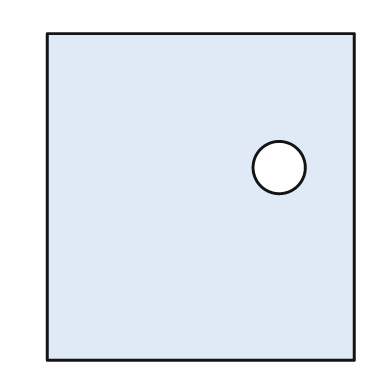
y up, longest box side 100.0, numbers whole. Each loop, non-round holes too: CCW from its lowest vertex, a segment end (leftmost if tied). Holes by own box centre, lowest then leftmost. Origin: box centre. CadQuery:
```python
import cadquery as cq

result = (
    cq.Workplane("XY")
    .moveTo(-47.0, -50.0)
    .lineTo(47.0, -50.0)
    .lineTo(47.0, 50.0)
    .lineTo(-47.0, 50.0)
    .close()
    .moveTo(24.0, 9.0)
    .circle(8.0)
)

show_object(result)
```